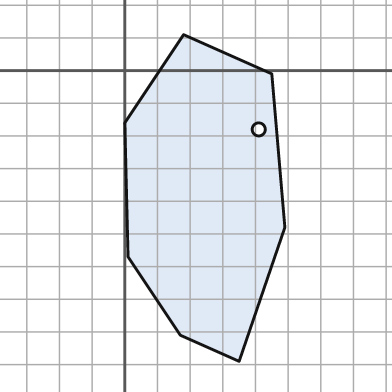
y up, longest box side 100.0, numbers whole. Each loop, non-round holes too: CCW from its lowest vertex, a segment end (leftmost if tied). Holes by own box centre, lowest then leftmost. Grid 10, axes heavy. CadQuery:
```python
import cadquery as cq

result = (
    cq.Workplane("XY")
    .moveTo(35.0, -89.0)
    .lineTo(49.0, -48.0)
    .lineTo(45.0, -1.0)
    .lineTo(18.0, 11.0)
    .lineTo(0.0, -16.0)
    .lineTo(1.0, -57.0)
    .lineTo(17.0, -81.0)
    .close()
    .moveTo(41.0, -18.0)
    .circle(2.0)
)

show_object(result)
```